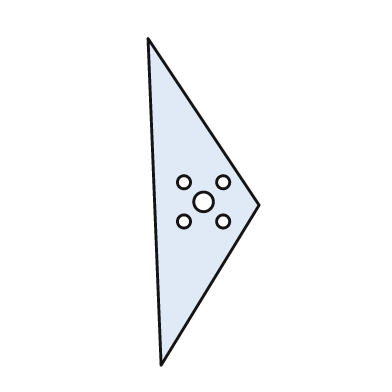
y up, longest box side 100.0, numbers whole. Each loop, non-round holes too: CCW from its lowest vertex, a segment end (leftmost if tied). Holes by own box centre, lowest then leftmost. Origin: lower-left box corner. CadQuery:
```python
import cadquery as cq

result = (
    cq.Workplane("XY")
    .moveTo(4.0, 0.0)
    .lineTo(34.0, 49.0)
    .lineTo(0.0, 100.0)
    .close()
    .moveTo(11.0, 44.0)
    .circle(2.0)
    .moveTo(23.0, 44.0)
    .circle(2.0)
    .moveTo(17.0, 50.0)
    .circle(3.0)
    .moveTo(11.0, 56.0)
    .circle(2.0)
    .moveTo(23.0, 56.0)
    .circle(2.0)
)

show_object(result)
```